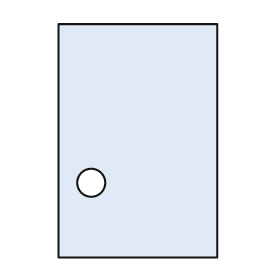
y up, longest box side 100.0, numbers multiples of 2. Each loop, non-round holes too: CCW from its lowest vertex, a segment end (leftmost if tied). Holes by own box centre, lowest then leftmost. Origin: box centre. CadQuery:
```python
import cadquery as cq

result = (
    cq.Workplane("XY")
    .moveTo(-34.0, -50.0)
    .lineTo(34.0, -50.0)
    .lineTo(34.0, 50.0)
    .lineTo(-34.0, 50.0)
    .close()
    .moveTo(-20.0, -18.0)
    .circle(6.0)
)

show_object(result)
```